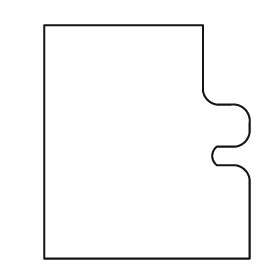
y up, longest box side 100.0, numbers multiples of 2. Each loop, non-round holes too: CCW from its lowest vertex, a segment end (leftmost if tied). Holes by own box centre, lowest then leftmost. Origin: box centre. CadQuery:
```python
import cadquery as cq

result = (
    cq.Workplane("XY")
    .moveTo(-44.0, -50.0)
    .lineTo(44.0, -50.0)
    .lineTo(44.0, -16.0)
    .threePointArc((42.0, -12.0), (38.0, -10.0))
    .lineTo(30.0, -10.0)
    .threePointArc((28.0, -6.0), (30.0, -2.0))
    .lineTo(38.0, -2.0)
    .threePointArc((42.0, 0.0), (44.0, 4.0))
    .lineTo(44.0, 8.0)
    .threePointArc((42.0, 14.0), (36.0, 16.0))
    .lineTo(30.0, 16.0)
    .threePointArc((26.0, 18.0), (24.0, 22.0))
    .lineTo(24.0, 50.0)
    .lineTo(-44.0, 50.0)
    .close()
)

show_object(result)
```